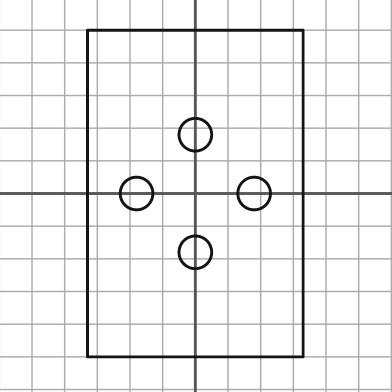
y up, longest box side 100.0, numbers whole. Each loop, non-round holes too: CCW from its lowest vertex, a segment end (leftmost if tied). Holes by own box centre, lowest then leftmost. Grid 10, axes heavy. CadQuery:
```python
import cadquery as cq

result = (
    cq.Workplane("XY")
    .moveTo(-33.0, -50.0)
    .lineTo(33.0, -50.0)
    .lineTo(33.0, 50.0)
    .lineTo(-33.0, 50.0)
    .close()
    .moveTo(0.0, -18.0)
    .circle(5.0)
    .moveTo(-18.0, 0.0)
    .circle(5.0)
    .moveTo(18.0, 0.0)
    .circle(5.0)
    .moveTo(0.0, 18.0)
    .circle(5.0)
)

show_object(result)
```